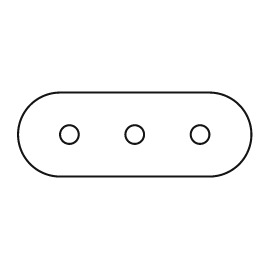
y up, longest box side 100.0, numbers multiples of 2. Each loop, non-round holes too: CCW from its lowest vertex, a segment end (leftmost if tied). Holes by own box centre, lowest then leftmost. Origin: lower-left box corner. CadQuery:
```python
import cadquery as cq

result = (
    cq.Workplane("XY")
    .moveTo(18.0, 0.0)
    .lineTo(82.0, 0.0)
    .threePointArc((100.0, 18.0), (82.0, 36.0))
    .lineTo(18.0, 36.0)
    .threePointArc((0.0, 18.0), (18.0, 0.0))
    .close()
    .moveTo(22.0, 18.0)
    .circle(4.0)
    .moveTo(50.0, 18.0)
    .circle(4.0)
    .moveTo(78.0, 18.0)
    .circle(4.0)
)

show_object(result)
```